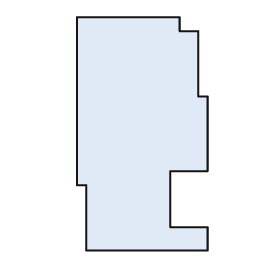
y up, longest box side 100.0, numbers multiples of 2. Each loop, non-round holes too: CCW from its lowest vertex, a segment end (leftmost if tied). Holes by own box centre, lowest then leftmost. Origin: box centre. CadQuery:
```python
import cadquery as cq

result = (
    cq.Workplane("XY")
    .moveTo(-24.0, -50.0)
    .lineTo(28.0, -50.0)
    .lineTo(28.0, -40.0)
    .lineTo(12.0, -40.0)
    .lineTo(12.0, -16.0)
    .lineTo(28.0, -16.0)
    .lineTo(28.0, 16.0)
    .lineTo(24.0, 16.0)
    .lineTo(24.0, 44.0)
    .lineTo(16.0, 44.0)
    .lineTo(16.0, 50.0)
    .lineTo(-28.0, 50.0)
    .lineTo(-28.0, -22.0)
    .lineTo(-24.0, -22.0)
    .close()
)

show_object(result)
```